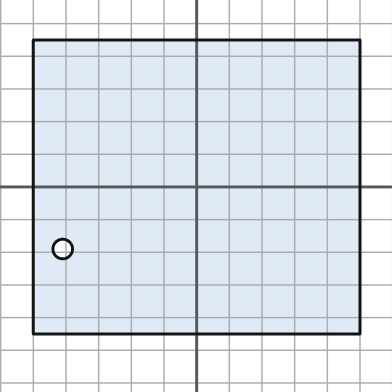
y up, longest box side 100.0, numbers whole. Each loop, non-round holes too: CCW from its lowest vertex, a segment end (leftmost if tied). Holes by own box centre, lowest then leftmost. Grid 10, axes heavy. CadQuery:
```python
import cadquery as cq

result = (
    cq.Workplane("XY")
    .moveTo(-50.0, -45.0)
    .lineTo(50.0, -45.0)
    .lineTo(50.0, 45.0)
    .lineTo(-50.0, 45.0)
    .close()
    .moveTo(-41.0, -19.0)
    .circle(3.0)
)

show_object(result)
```